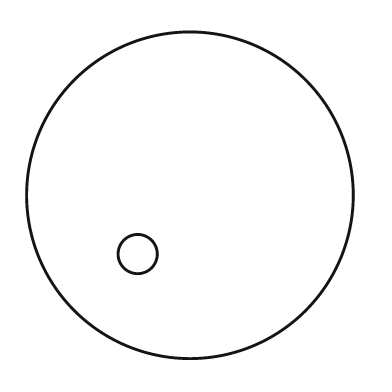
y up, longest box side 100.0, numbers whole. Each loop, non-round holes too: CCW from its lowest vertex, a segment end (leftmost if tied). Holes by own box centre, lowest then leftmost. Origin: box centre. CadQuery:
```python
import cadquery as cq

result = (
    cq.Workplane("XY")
    .moveTo(0.0, 0.0)
    .circle(50.0)
    .moveTo(-16.0, -18.0)
    .circle(6.0)
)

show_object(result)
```